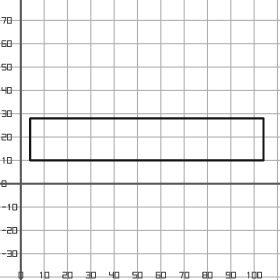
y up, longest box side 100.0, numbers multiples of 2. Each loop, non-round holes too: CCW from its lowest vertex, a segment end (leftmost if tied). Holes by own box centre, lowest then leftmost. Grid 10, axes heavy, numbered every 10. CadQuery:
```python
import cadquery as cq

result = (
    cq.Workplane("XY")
    .moveTo(4.0, 10.0)
    .lineTo(104.0, 10.0)
    .lineTo(104.0, 28.0)
    .lineTo(4.0, 28.0)
    .close()
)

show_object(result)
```